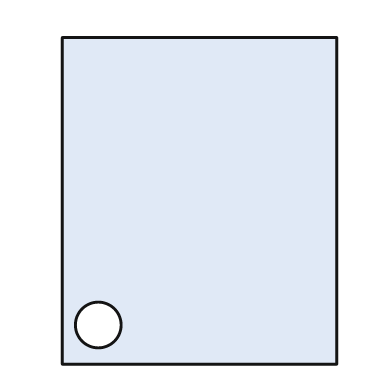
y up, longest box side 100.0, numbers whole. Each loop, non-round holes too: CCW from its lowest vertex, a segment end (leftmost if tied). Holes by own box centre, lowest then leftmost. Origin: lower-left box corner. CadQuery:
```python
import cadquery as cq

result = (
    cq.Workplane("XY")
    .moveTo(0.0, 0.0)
    .lineTo(84.0, 0.0)
    .lineTo(84.0, 100.0)
    .lineTo(0.0, 100.0)
    .close()
    .moveTo(11.0, 12.0)
    .circle(7.0)
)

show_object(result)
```